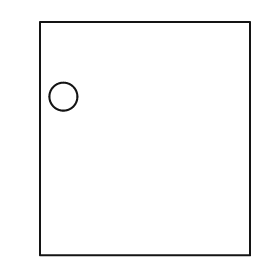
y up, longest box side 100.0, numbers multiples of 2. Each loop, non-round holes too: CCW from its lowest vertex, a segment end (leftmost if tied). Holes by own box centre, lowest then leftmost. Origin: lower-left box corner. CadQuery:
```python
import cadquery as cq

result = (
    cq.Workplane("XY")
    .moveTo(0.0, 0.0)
    .lineTo(90.0, 0.0)
    .lineTo(90.0, 100.0)
    .lineTo(0.0, 100.0)
    .close()
    .moveTo(10.0, 68.0)
    .circle(6.0)
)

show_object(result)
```